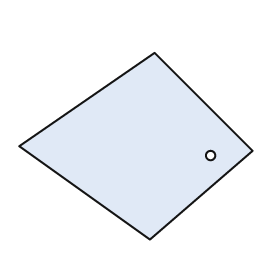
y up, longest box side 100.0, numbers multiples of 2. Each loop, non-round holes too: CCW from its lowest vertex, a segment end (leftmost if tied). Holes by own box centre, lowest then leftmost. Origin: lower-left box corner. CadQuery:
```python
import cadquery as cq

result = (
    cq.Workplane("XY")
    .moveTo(56.0, 0.0)
    .lineTo(100.0, 38.0)
    .lineTo(58.0, 80.0)
    .lineTo(0.0, 40.0)
    .close()
    .moveTo(82.0, 36.0)
    .circle(2.0)
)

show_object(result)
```